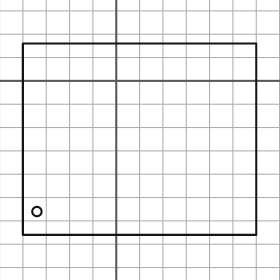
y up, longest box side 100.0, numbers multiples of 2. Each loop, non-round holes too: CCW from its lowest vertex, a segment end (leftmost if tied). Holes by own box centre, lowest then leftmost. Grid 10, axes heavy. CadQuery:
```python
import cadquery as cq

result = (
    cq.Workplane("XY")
    .moveTo(-40.0, -66.0)
    .lineTo(60.0, -66.0)
    .lineTo(60.0, 16.0)
    .lineTo(-40.0, 16.0)
    .close()
    .moveTo(-34.0, -56.0)
    .circle(2.0)
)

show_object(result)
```